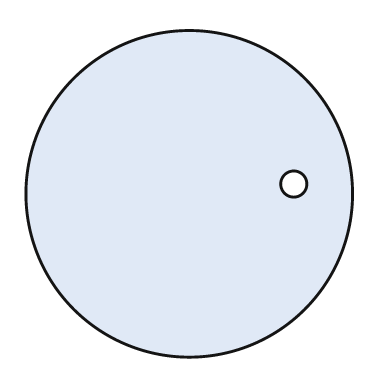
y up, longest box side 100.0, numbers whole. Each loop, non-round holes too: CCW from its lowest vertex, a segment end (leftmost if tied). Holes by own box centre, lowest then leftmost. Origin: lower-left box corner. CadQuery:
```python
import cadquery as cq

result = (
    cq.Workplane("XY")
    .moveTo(50.0, 50.0)
    .circle(50.0)
    .moveTo(82.0, 53.0)
    .circle(4.0)
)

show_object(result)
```